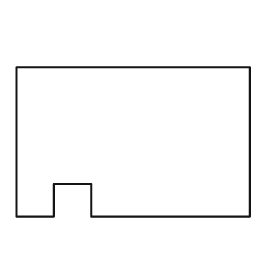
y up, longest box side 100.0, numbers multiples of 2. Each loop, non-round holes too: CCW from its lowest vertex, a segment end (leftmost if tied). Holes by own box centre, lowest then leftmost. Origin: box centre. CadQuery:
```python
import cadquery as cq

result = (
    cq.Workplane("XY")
    .moveTo(-50.0, -32.0)
    .lineTo(-34.0, -32.0)
    .lineTo(-34.0, -18.0)
    .lineTo(-18.0, -18.0)
    .lineTo(-18.0, -32.0)
    .lineTo(50.0, -32.0)
    .lineTo(50.0, 32.0)
    .lineTo(-50.0, 32.0)
    .close()
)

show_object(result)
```